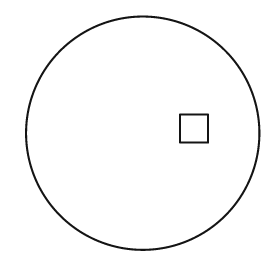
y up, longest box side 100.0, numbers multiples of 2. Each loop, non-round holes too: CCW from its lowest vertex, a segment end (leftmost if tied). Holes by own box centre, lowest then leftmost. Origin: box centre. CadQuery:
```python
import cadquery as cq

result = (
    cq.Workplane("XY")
    .moveTo(0.0, 0.0)
    .circle(50.0)
    .moveTo(16.0, -4.0)
    .lineTo(28.0, -4.0)
    .lineTo(28.0, 8.0)
    .lineTo(16.0, 8.0)
    .close()
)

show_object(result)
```